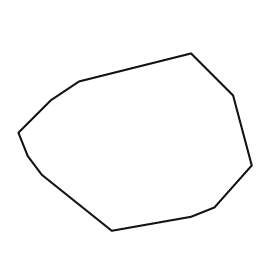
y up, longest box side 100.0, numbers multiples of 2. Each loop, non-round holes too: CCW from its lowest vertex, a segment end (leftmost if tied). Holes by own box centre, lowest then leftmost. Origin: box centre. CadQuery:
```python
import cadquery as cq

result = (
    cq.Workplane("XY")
    .moveTo(-10.0, -38.0)
    .lineTo(24.0, -32.0)
    .lineTo(34.0, -28.0)
    .lineTo(50.0, -10.0)
    .lineTo(42.0, 20.0)
    .lineTo(24.0, 38.0)
    .lineTo(-24.0, 26.0)
    .lineTo(-36.0, 18.0)
    .lineTo(-50.0, 4.0)
    .lineTo(-46.0, -6.0)
    .lineTo(-40.0, -14.0)
    .close()
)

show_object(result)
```